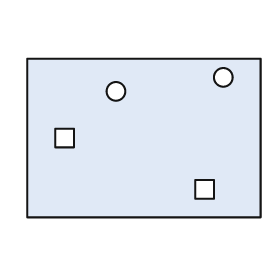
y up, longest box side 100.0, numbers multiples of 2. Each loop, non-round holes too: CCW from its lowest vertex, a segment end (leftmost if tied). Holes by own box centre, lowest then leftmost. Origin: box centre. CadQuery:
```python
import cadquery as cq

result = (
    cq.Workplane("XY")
    .moveTo(-50.0, -34.0)
    .lineTo(50.0, -34.0)
    .lineTo(50.0, 34.0)
    .lineTo(-50.0, 34.0)
    .close()
    .moveTo(22.0, -26.0)
    .lineTo(30.0, -26.0)
    .lineTo(30.0, -18.0)
    .lineTo(22.0, -18.0)
    .close()
    .moveTo(-38.0, -4.0)
    .lineTo(-30.0, -4.0)
    .lineTo(-30.0, 4.0)
    .lineTo(-38.0, 4.0)
    .close()
    .moveTo(-12.0, 20.0)
    .circle(4.0)
    .moveTo(34.0, 26.0)
    .circle(4.0)
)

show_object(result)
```